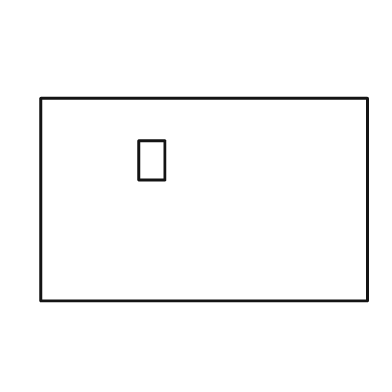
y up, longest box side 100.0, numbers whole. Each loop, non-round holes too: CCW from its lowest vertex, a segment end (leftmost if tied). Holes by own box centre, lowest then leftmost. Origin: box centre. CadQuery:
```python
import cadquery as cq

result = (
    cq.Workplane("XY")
    .moveTo(-50.0, -31.0)
    .lineTo(50.0, -31.0)
    .lineTo(50.0, 31.0)
    .lineTo(-50.0, 31.0)
    .close()
    .moveTo(-20.0, 6.0)
    .lineTo(-12.0, 6.0)
    .lineTo(-12.0, 18.0)
    .lineTo(-20.0, 18.0)
    .close()
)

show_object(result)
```